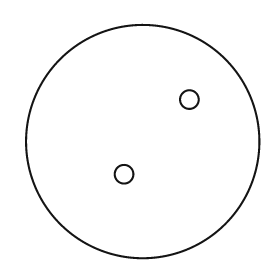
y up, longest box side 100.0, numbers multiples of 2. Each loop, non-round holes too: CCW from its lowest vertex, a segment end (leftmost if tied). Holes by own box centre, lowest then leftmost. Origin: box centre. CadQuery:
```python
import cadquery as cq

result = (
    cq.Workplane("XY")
    .moveTo(0.0, 0.0)
    .circle(50.0)
    .moveTo(-8.0, -14.0)
    .circle(4.0)
    .moveTo(20.0, 18.0)
    .circle(4.0)
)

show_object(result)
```